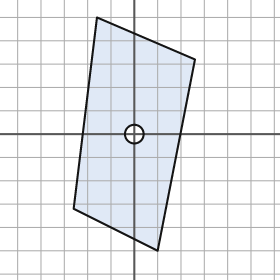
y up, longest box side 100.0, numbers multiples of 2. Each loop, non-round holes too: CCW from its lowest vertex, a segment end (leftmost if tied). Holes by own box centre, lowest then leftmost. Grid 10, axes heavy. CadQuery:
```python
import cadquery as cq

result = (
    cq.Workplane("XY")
    .moveTo(10.0, -50.0)
    .lineTo(26.0, 32.0)
    .lineTo(-16.0, 50.0)
    .lineTo(-26.0, -32.0)
    .close()
    .moveTo(0.0, 0.0)
    .circle(4.0)
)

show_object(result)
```